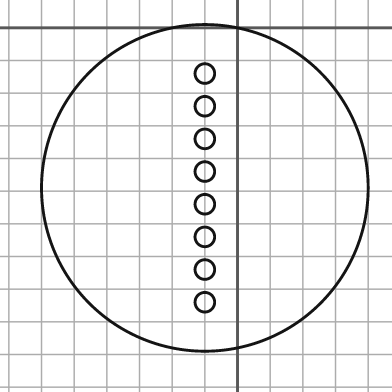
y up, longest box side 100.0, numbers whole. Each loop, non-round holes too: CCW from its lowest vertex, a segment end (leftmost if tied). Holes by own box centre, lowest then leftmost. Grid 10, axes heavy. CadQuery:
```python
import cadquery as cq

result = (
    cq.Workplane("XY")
    .moveTo(-10.0, -49.0)
    .circle(50.0)
    .moveTo(-10.0, -84.0)
    .circle(3.0)
    .moveTo(-10.0, -74.0)
    .circle(3.0)
    .moveTo(-10.0, -64.0)
    .circle(3.0)
    .moveTo(-10.0, -54.0)
    .circle(3.0)
    .moveTo(-10.0, -44.0)
    .circle(3.0)
    .moveTo(-10.0, -34.0)
    .circle(3.0)
    .moveTo(-10.0, -24.0)
    .circle(3.0)
    .moveTo(-10.0, -14.0)
    .circle(3.0)
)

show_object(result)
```